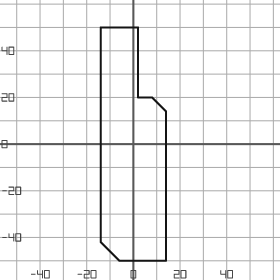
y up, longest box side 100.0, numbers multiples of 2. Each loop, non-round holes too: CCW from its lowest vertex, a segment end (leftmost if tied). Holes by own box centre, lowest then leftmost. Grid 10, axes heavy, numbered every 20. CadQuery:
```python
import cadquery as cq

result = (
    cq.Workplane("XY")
    .moveTo(-6.0, -50.0)
    .lineTo(14.0, -50.0)
    .lineTo(14.0, 14.0)
    .lineTo(8.0, 20.0)
    .lineTo(2.0, 20.0)
    .lineTo(2.0, 50.0)
    .lineTo(-14.0, 50.0)
    .lineTo(-14.0, -42.0)
    .close()
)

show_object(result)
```